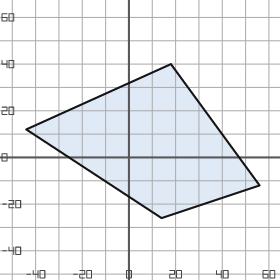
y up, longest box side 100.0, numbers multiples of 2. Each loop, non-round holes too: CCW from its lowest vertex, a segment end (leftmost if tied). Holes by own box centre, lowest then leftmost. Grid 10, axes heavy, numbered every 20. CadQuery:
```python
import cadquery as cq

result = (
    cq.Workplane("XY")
    .moveTo(14.0, -26.0)
    .lineTo(56.0, -12.0)
    .lineTo(18.0, 40.0)
    .lineTo(-44.0, 12.0)
    .close()
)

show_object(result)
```